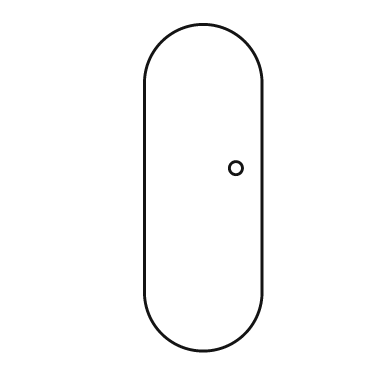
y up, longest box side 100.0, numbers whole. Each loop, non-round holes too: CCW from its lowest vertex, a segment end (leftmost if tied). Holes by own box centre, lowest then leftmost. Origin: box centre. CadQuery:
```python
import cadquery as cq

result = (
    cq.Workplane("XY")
    .moveTo(-18.0, -32.0)
    .threePointArc((0.0, -50.0), (18.0, -32.0))
    .lineTo(18.0, 32.0)
    .threePointArc((0.0, 50.0), (-18.0, 32.0))
    .close()
    .moveTo(10.0, 6.0)
    .circle(2.0)
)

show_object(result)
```